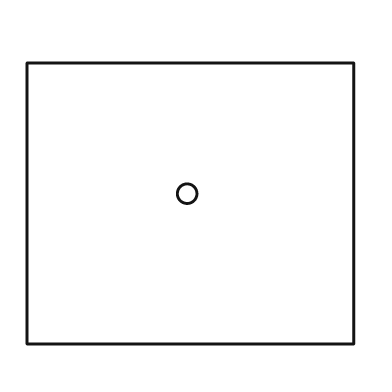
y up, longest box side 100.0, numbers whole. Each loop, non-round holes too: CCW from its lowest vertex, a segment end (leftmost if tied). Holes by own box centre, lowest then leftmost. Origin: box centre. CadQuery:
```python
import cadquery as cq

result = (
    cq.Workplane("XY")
    .moveTo(-50.0, -43.0)
    .lineTo(50.0, -43.0)
    .lineTo(50.0, 43.0)
    .lineTo(-50.0, 43.0)
    .close()
    .moveTo(-1.0, 3.0)
    .circle(3.0)
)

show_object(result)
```